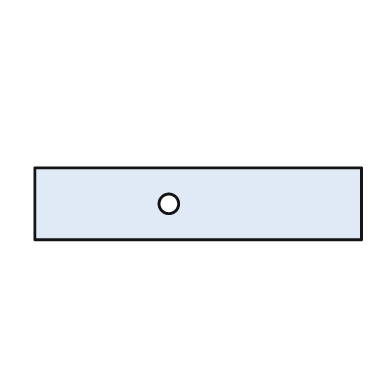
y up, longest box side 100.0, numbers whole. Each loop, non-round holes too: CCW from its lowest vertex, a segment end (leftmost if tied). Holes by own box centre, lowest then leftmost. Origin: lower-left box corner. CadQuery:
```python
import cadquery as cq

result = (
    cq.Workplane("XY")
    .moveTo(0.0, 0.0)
    .lineTo(100.0, 0.0)
    .lineTo(100.0, 22.0)
    .lineTo(0.0, 22.0)
    .close()
    .moveTo(41.0, 11.0)
    .circle(3.0)
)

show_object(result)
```